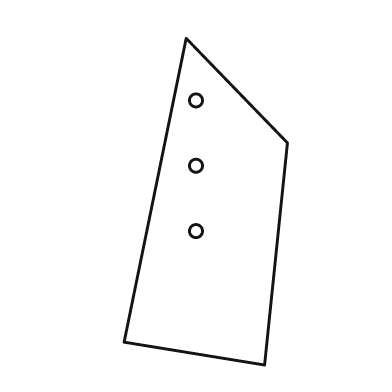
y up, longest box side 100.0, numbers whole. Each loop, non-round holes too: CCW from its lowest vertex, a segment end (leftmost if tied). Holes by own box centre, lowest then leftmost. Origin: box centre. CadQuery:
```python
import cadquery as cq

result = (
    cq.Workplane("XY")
    .moveTo(18.0, -50.0)
    .lineTo(25.0, 18.0)
    .lineTo(-6.0, 50.0)
    .lineTo(-25.0, -43.0)
    .close()
    .moveTo(-3.0, -9.0)
    .circle(2.0)
    .moveTo(-3.0, 11.0)
    .circle(2.0)
    .moveTo(-3.0, 31.0)
    .circle(2.0)
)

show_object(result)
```